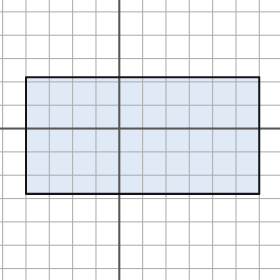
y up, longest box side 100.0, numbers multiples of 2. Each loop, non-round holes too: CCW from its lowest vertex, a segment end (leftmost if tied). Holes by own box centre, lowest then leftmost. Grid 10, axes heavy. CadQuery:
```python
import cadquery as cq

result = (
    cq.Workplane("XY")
    .moveTo(-40.0, -28.0)
    .lineTo(60.0, -28.0)
    .lineTo(60.0, 22.0)
    .lineTo(-40.0, 22.0)
    .close()
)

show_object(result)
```